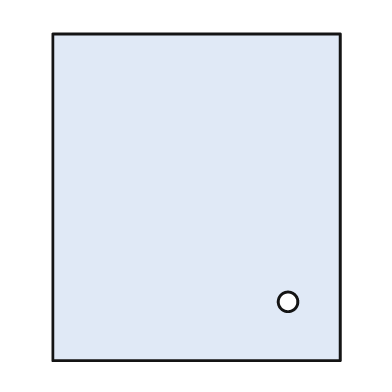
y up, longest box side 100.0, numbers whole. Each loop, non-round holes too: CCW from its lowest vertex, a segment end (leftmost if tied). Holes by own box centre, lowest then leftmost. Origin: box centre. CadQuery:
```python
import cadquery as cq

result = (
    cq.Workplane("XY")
    .moveTo(-44.0, -50.0)
    .lineTo(44.0, -50.0)
    .lineTo(44.0, 50.0)
    .lineTo(-44.0, 50.0)
    .close()
    .moveTo(28.0, -32.0)
    .circle(3.0)
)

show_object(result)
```